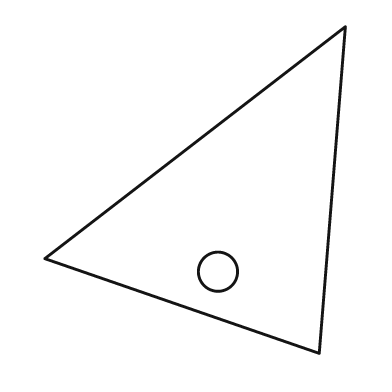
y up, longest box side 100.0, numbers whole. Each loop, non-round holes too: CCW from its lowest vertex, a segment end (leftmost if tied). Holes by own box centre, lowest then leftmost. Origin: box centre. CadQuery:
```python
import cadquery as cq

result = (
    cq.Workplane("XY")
    .moveTo(38.0, -50.0)
    .lineTo(46.0, 50.0)
    .lineTo(-46.0, -21.0)
    .close()
    .moveTo(7.0, -25.0)
    .circle(6.0)
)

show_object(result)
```